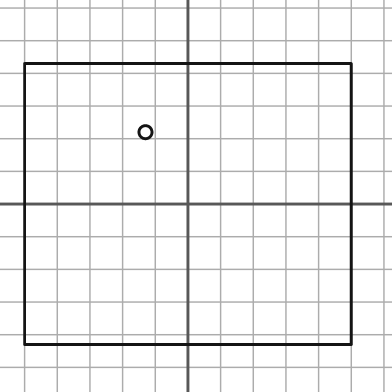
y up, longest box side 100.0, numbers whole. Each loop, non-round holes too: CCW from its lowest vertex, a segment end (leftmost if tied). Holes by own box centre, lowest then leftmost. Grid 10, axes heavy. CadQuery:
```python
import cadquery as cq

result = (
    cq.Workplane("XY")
    .moveTo(-50.0, -43.0)
    .lineTo(50.0, -43.0)
    .lineTo(50.0, 43.0)
    .lineTo(-50.0, 43.0)
    .close()
    .moveTo(-13.0, 22.0)
    .circle(2.0)
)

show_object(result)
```